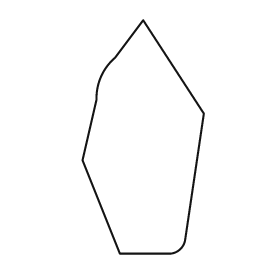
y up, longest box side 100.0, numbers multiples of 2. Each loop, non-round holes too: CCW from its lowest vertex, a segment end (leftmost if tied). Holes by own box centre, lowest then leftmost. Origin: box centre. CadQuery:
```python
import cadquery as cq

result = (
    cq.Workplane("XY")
    .moveTo(-10.0, -50.0)
    .lineTo(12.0, -50.0)
    .threePointArc((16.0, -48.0), (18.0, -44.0))
    .lineTo(26.0, 10.0)
    .lineTo(0.0, 50.0)
    .lineTo(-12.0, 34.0)
    .threePointArc((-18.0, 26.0), (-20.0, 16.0))
    .lineTo(-26.0, -10.0)
    .close()
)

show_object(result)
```